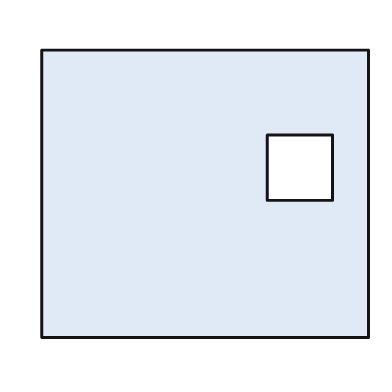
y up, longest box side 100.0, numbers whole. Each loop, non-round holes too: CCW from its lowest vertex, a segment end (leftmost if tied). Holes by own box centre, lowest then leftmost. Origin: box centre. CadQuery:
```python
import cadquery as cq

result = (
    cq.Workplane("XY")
    .moveTo(-50.0, -44.0)
    .lineTo(50.0, -44.0)
    .lineTo(50.0, 44.0)
    .lineTo(-50.0, 44.0)
    .close()
    .moveTo(19.0, -2.0)
    .lineTo(39.0, -2.0)
    .lineTo(39.0, 18.0)
    .lineTo(19.0, 18.0)
    .close()
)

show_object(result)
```